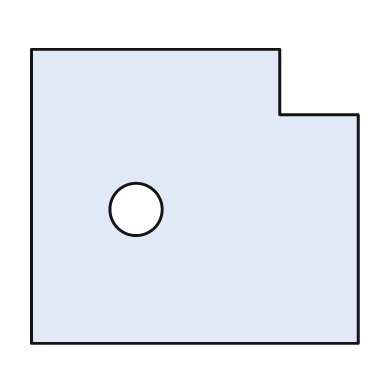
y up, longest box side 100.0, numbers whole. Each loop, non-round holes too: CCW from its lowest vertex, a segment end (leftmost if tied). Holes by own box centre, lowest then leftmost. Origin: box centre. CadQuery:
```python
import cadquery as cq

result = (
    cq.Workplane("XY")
    .moveTo(-50.0, -45.0)
    .lineTo(50.0, -45.0)
    .lineTo(50.0, 25.0)
    .lineTo(26.0, 25.0)
    .lineTo(26.0, 45.0)
    .lineTo(-50.0, 45.0)
    .close()
    .moveTo(-18.0, -4.0)
    .circle(8.0)
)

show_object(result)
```